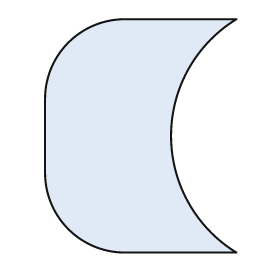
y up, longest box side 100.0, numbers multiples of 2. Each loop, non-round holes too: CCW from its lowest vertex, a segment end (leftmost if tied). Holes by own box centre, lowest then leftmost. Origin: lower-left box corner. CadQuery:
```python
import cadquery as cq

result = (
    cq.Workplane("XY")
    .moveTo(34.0, 0.0)
    .lineTo(82.0, 0.0)
    .threePointArc((54.0, 50.0), (82.0, 100.0))
    .lineTo(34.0, 100.0)
    .threePointArc((10.0, 90.0), (0.0, 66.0))
    .lineTo(0.0, 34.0)
    .threePointArc((10.0, 10.0), (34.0, 0.0))
    .close()
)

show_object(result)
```